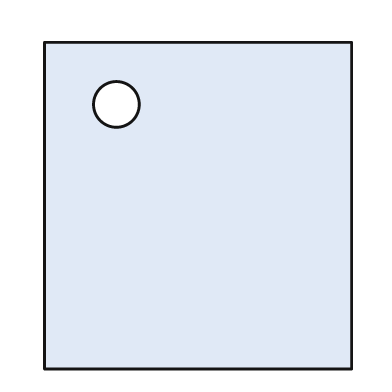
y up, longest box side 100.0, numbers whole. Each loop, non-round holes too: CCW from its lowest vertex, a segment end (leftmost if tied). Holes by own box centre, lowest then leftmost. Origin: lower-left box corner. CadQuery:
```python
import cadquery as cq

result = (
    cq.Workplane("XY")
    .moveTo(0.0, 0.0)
    .lineTo(94.0, 0.0)
    .lineTo(94.0, 100.0)
    .lineTo(0.0, 100.0)
    .close()
    .moveTo(22.0, 81.0)
    .circle(7.0)
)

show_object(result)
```